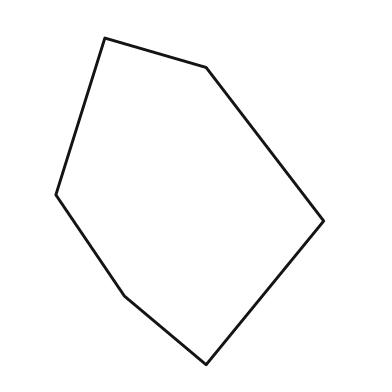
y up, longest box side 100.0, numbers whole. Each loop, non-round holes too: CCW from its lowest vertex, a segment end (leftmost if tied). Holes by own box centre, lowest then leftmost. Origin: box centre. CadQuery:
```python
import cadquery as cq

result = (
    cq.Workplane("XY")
    .moveTo(5.0, -50.0)
    .lineTo(41.0, -6.0)
    .lineTo(5.0, 41.0)
    .lineTo(-26.0, 50.0)
    .lineTo(-41.0, 2.0)
    .lineTo(-20.0, -29.0)
    .close()
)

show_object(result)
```